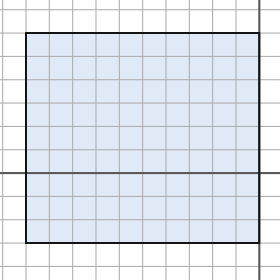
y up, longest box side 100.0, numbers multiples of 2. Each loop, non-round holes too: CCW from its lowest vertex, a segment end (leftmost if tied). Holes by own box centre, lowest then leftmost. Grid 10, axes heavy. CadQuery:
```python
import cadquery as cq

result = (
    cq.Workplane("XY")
    .moveTo(-100.0, -30.0)
    .lineTo(0.0, -30.0)
    .lineTo(0.0, 60.0)
    .lineTo(-100.0, 60.0)
    .close()
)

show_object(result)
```